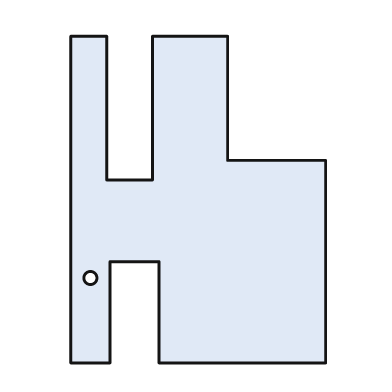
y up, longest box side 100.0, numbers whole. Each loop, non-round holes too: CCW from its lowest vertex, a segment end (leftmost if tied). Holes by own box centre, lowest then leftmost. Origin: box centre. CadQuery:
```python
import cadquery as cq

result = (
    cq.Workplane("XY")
    .moveTo(-39.0, -50.0)
    .lineTo(-27.0, -50.0)
    .lineTo(-27.0, -19.0)
    .lineTo(-12.0, -19.0)
    .lineTo(-12.0, -50.0)
    .lineTo(39.0, -50.0)
    .lineTo(39.0, 12.0)
    .lineTo(9.0, 12.0)
    .lineTo(9.0, 50.0)
    .lineTo(-14.0, 50.0)
    .lineTo(-14.0, 6.0)
    .lineTo(-28.0, 6.0)
    .lineTo(-28.0, 50.0)
    .lineTo(-39.0, 50.0)
    .close()
    .moveTo(-33.0, -24.0)
    .circle(2.0)
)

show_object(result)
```